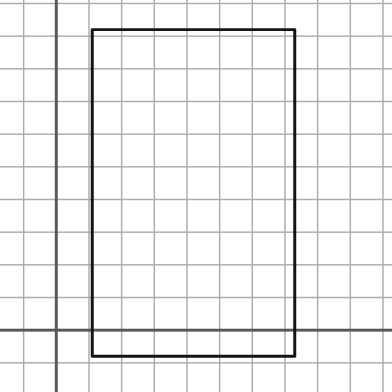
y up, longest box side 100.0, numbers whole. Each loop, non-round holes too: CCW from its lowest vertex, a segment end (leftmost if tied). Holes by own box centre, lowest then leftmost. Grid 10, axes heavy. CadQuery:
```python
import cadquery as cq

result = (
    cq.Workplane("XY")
    .moveTo(11.0, -8.0)
    .lineTo(73.0, -8.0)
    .lineTo(73.0, 92.0)
    .lineTo(11.0, 92.0)
    .close()
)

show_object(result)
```